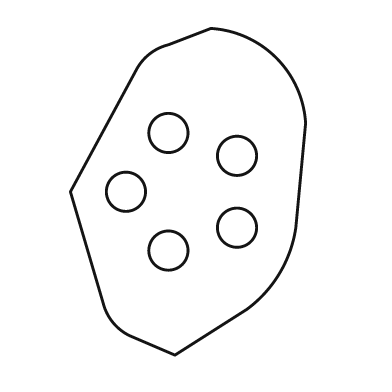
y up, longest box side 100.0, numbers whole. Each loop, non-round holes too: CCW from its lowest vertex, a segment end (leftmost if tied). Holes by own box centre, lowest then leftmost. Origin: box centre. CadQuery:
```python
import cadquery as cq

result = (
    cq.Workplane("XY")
    .moveTo(-4.0, -50.0)
    .lineTo(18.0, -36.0)
    .threePointArc((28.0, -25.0), (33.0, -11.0))
    .lineTo(36.0, 21.0)
    .threePointArc((27.0, 41.0), (7.0, 50.0))
    .lineTo(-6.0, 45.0)
    .threePointArc((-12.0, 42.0), (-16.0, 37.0))
    .lineTo(-36.0, 0.0)
    .lineTo(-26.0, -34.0)
    .threePointArc((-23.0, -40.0), (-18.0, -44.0))
    .close()
    .moveTo(-6.0, -18.0)
    .circle(6.0)
    .moveTo(15.0, -11.0)
    .circle(6.0)
    .moveTo(-19.0, 0.0)
    .circle(6.0)
    .moveTo(15.0, 11.0)
    .circle(6.0)
    .moveTo(-6.0, 18.0)
    .circle(6.0)
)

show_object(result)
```